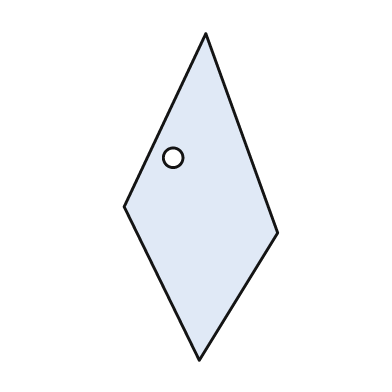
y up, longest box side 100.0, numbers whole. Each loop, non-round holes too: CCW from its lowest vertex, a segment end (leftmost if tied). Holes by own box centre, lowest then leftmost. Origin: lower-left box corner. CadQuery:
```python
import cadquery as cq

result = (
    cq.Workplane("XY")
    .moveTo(23.0, 0.0)
    .lineTo(47.0, 39.0)
    .lineTo(25.0, 100.0)
    .lineTo(0.0, 47.0)
    .close()
    .moveTo(15.0, 62.0)
    .circle(3.0)
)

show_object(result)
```